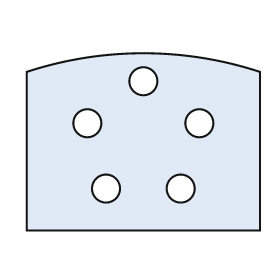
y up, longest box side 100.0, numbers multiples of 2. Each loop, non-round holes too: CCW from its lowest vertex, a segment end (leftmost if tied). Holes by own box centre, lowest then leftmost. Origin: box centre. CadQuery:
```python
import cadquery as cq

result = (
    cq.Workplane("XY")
    .moveTo(-50.0, -38.0)
    .lineTo(50.0, -38.0)
    .lineTo(50.0, 30.0)
    .threePointArc((0.0, 38.0), (-50.0, 30.0))
    .close()
    .moveTo(-16.0, -20.0)
    .circle(6.0)
    .moveTo(16.0, -20.0)
    .circle(6.0)
    .moveTo(-24.0, 8.0)
    .circle(6.0)
    .moveTo(24.0, 8.0)
    .circle(6.0)
    .moveTo(0.0, 26.0)
    .circle(6.0)
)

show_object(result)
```